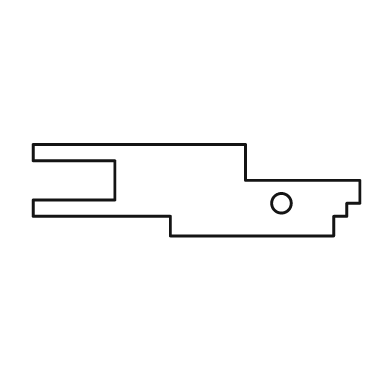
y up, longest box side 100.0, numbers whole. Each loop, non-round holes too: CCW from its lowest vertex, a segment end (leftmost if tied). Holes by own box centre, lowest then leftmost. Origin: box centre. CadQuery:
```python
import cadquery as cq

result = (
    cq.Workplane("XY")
    .moveTo(-8.0, -14.0)
    .lineTo(42.0, -14.0)
    .lineTo(42.0, -8.0)
    .lineTo(46.0, -8.0)
    .lineTo(46.0, -4.0)
    .lineTo(50.0, -4.0)
    .lineTo(50.0, 3.0)
    .lineTo(15.0, 3.0)
    .lineTo(15.0, 14.0)
    .lineTo(-50.0, 14.0)
    .lineTo(-50.0, 9.0)
    .lineTo(-25.0, 9.0)
    .lineTo(-25.0, -3.0)
    .lineTo(-50.0, -3.0)
    .lineTo(-50.0, -8.0)
    .lineTo(-8.0, -8.0)
    .close()
    .moveTo(26.0, -4.0)
    .circle(3.0)
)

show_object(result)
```